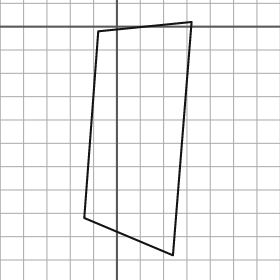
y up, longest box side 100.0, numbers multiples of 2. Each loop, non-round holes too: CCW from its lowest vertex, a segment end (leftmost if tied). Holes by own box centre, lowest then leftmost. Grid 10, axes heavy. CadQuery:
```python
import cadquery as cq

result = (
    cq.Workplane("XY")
    .moveTo(24.0, -98.0)
    .lineTo(32.0, 2.0)
    .lineTo(-8.0, -2.0)
    .lineTo(-14.0, -82.0)
    .close()
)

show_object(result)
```